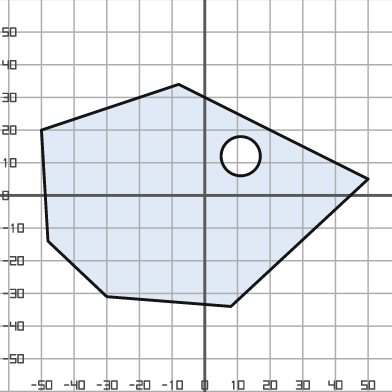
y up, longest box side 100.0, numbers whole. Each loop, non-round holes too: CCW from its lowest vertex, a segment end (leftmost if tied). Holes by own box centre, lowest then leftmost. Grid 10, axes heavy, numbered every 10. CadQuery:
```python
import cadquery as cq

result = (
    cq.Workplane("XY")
    .moveTo(8.0, -34.0)
    .lineTo(50.0, 5.0)
    .lineTo(-8.0, 34.0)
    .lineTo(-50.0, 20.0)
    .lineTo(-48.0, -14.0)
    .lineTo(-30.0, -31.0)
    .close()
    .moveTo(11.0, 12.0)
    .circle(6.0)
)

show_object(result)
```